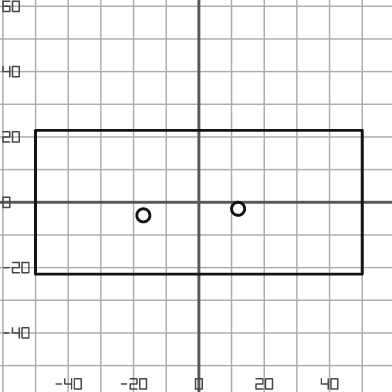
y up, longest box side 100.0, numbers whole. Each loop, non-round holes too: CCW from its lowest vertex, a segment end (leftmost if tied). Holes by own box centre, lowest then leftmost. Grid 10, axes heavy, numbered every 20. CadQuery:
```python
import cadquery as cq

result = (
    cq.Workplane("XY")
    .moveTo(-50.0, -22.0)
    .lineTo(50.0, -22.0)
    .lineTo(50.0, 22.0)
    .lineTo(-50.0, 22.0)
    .close()
    .moveTo(-17.0, -4.0)
    .circle(2.0)
    .moveTo(12.0, -2.0)
    .circle(2.0)
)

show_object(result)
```